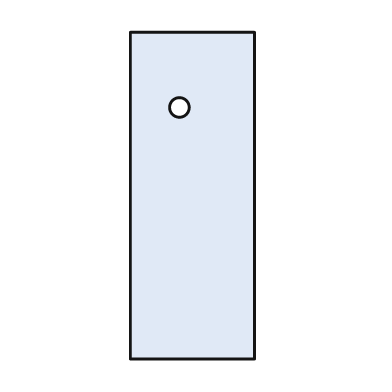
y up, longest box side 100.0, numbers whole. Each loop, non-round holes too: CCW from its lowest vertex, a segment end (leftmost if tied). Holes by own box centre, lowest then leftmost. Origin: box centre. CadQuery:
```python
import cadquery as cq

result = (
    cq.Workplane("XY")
    .moveTo(-19.0, -50.0)
    .lineTo(19.0, -50.0)
    .lineTo(19.0, 50.0)
    .lineTo(-19.0, 50.0)
    .close()
    .moveTo(-4.0, 27.0)
    .circle(3.0)
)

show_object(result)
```